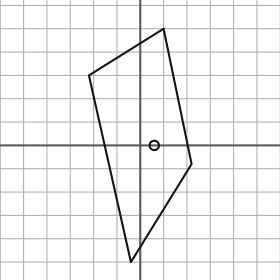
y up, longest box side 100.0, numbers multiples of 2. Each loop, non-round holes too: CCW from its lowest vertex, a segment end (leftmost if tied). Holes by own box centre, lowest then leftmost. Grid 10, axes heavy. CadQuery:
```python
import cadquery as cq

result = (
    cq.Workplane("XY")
    .moveTo(-4.0, -50.0)
    .lineTo(22.0, -8.0)
    .lineTo(10.0, 50.0)
    .lineTo(-22.0, 30.0)
    .close()
    .moveTo(6.0, 0.0)
    .circle(2.0)
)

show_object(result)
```